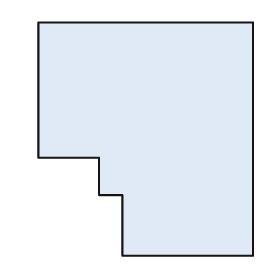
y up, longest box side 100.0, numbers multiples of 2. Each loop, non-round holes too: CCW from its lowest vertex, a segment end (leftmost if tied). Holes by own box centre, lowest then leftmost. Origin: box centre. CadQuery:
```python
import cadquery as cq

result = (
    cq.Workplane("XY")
    .moveTo(-10.0, -50.0)
    .lineTo(46.0, -50.0)
    .lineTo(46.0, 50.0)
    .lineTo(-46.0, 50.0)
    .lineTo(-46.0, -8.0)
    .lineTo(-20.0, -8.0)
    .lineTo(-20.0, -24.0)
    .lineTo(-10.0, -24.0)
    .close()
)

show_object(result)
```